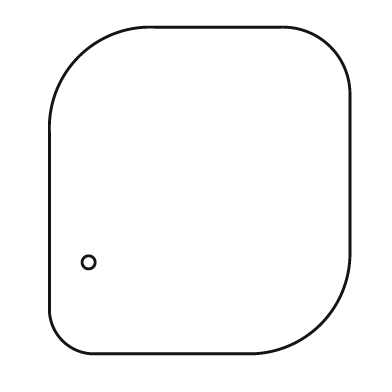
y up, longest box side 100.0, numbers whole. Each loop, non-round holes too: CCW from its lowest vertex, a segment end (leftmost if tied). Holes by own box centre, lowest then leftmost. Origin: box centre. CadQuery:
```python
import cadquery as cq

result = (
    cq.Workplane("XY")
    .moveTo(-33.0, -50.0)
    .lineTo(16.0, -50.0)
    .threePointArc((37.0, -41.0), (46.0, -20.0))
    .lineTo(46.0, 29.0)
    .threePointArc((40.0, 44.0), (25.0, 50.0))
    .lineTo(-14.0, 50.0)
    .threePointArc((-37.0, 41.0), (-46.0, 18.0))
    .lineTo(-46.0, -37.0)
    .threePointArc((-42.0, -46.0), (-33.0, -50.0))
    .close()
    .moveTo(-34.0, -22.0)
    .circle(2.0)
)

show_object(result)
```